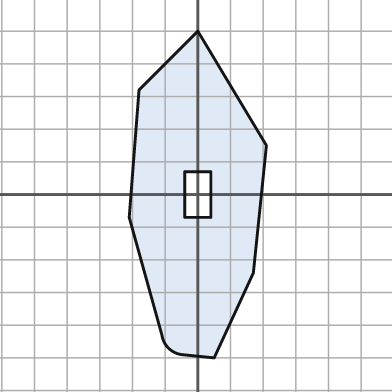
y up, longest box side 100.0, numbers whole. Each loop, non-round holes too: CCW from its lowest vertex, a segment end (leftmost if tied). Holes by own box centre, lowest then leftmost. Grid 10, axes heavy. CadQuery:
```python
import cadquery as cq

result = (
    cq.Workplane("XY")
    .moveTo(5.0, -50.0)
    .lineTo(17.0, -24.0)
    .lineTo(21.0, 15.0)
    .lineTo(0.0, 50.0)
    .lineTo(-18.0, 32.0)
    .lineTo(-21.0, -7.0)
    .lineTo(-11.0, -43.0)
    .threePointArc((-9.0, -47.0), (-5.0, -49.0))
    .close()
    .moveTo(-4.0, -7.0)
    .lineTo(4.0, -7.0)
    .lineTo(4.0, 7.0)
    .lineTo(-4.0, 7.0)
    .close()
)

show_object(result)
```